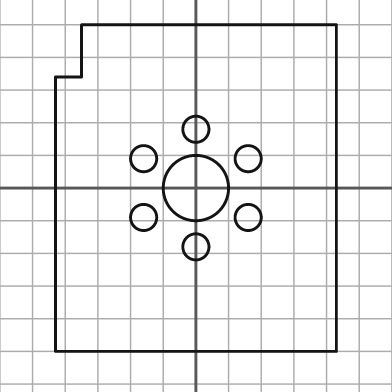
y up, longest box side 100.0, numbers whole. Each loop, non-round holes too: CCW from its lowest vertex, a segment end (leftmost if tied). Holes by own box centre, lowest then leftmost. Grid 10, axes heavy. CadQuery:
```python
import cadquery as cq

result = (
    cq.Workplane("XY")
    .moveTo(-43.0, -50.0)
    .lineTo(43.0, -50.0)
    .lineTo(43.0, 50.0)
    .lineTo(-35.0, 50.0)
    .lineTo(-35.0, 34.0)
    .lineTo(-43.0, 34.0)
    .close()
    .moveTo(0.0, -18.0)
    .circle(4.0)
    .moveTo(-16.0, -9.0)
    .circle(4.0)
    .moveTo(16.0, -9.0)
    .circle(4.0)
    .moveTo(0.0, 0.0)
    .circle(10.0)
    .moveTo(-16.0, 9.0)
    .circle(4.0)
    .moveTo(16.0, 9.0)
    .circle(4.0)
    .moveTo(0.0, 18.0)
    .circle(4.0)
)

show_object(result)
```